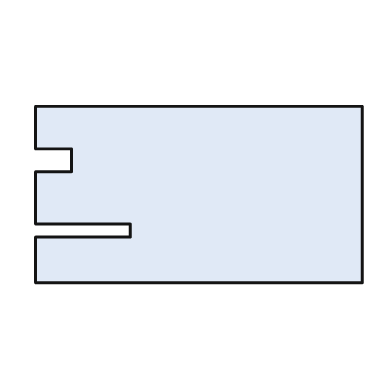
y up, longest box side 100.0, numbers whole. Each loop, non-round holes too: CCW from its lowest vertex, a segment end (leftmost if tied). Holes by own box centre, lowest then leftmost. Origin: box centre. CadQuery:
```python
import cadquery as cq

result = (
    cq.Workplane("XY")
    .moveTo(-50.0, -27.0)
    .lineTo(50.0, -27.0)
    .lineTo(50.0, 27.0)
    .lineTo(-50.0, 27.0)
    .lineTo(-50.0, 14.0)
    .lineTo(-39.0, 14.0)
    .lineTo(-39.0, 7.0)
    .lineTo(-50.0, 7.0)
    .lineTo(-50.0, -9.0)
    .lineTo(-21.0, -9.0)
    .lineTo(-21.0, -13.0)
    .lineTo(-50.0, -13.0)
    .close()
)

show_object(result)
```